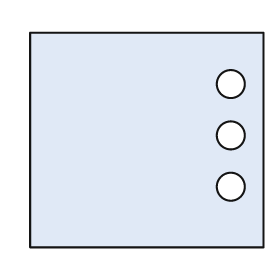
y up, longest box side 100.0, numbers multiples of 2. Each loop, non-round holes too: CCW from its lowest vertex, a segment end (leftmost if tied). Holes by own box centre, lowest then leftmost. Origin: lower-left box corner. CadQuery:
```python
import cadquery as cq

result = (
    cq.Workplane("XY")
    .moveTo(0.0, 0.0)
    .lineTo(100.0, 0.0)
    .lineTo(100.0, 92.0)
    .lineTo(0.0, 92.0)
    .close()
    .moveTo(86.0, 26.0)
    .circle(6.0)
    .moveTo(86.0, 48.0)
    .circle(6.0)
    .moveTo(86.0, 70.0)
    .circle(6.0)
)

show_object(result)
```